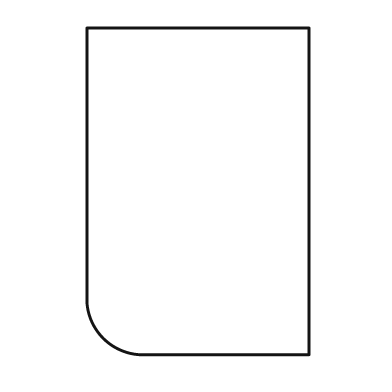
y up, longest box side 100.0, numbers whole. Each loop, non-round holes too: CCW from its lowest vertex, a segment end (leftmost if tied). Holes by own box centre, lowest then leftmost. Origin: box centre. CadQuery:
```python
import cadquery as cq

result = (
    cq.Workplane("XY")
    .moveTo(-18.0, -50.0)
    .lineTo(34.0, -50.0)
    .lineTo(34.0, 50.0)
    .lineTo(-34.0, 50.0)
    .lineTo(-34.0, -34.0)
    .threePointArc((-29.0, -45.0), (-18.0, -50.0))
    .close()
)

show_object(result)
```